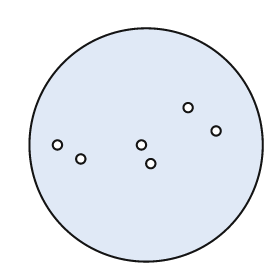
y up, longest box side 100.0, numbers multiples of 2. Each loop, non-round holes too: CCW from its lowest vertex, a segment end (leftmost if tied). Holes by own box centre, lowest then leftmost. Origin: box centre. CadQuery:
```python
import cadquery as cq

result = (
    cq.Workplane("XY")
    .moveTo(0.0, 0.0)
    .circle(50.0)
    .moveTo(2.0, -8.0)
    .circle(2.0)
    .moveTo(-28.0, -6.0)
    .circle(2.0)
    .moveTo(-38.0, 0.0)
    .circle(2.0)
    .moveTo(-2.0, 0.0)
    .circle(2.0)
    .moveTo(30.0, 6.0)
    .circle(2.0)
    .moveTo(18.0, 16.0)
    .circle(2.0)
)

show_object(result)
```